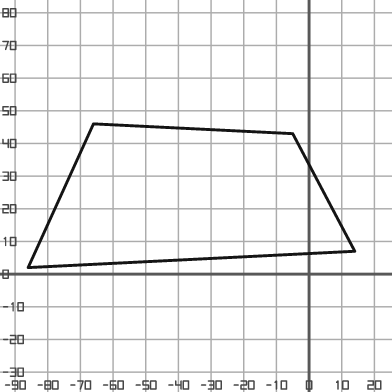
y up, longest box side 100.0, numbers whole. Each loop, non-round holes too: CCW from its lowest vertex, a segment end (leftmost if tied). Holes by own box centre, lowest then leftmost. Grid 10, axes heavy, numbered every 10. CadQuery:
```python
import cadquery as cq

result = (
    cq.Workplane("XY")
    .moveTo(-86.0, 2.0)
    .lineTo(14.0, 7.0)
    .lineTo(-5.0, 43.0)
    .lineTo(-66.0, 46.0)
    .close()
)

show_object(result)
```